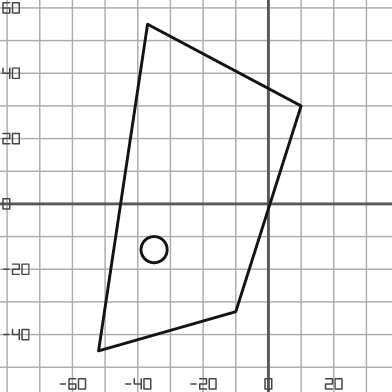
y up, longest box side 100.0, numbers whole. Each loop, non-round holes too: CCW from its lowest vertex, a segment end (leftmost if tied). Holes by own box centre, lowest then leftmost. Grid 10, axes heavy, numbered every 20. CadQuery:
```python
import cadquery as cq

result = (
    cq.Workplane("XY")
    .moveTo(-52.0, -45.0)
    .lineTo(-10.0, -33.0)
    .lineTo(10.0, 30.0)
    .lineTo(-37.0, 55.0)
    .close()
    .moveTo(-35.0, -14.0)
    .circle(4.0)
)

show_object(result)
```